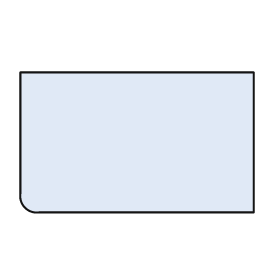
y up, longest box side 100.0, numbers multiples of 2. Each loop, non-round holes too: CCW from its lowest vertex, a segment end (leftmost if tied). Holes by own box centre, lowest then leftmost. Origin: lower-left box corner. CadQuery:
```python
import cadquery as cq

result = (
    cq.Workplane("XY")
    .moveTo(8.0, 0.0)
    .lineTo(100.0, 0.0)
    .lineTo(100.0, 60.0)
    .lineTo(0.0, 60.0)
    .lineTo(0.0, 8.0)
    .threePointArc((2.0, 2.0), (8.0, 0.0))
    .close()
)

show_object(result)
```